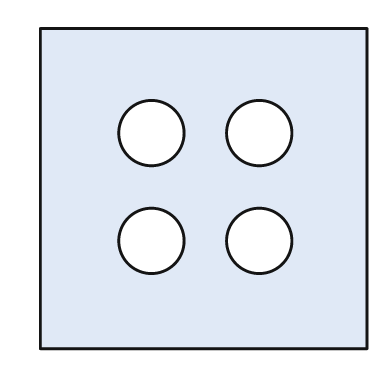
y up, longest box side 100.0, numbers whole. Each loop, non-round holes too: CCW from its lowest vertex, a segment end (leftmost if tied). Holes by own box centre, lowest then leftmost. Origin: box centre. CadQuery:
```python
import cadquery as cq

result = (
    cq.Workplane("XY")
    .moveTo(-50.0, -49.0)
    .lineTo(50.0, -49.0)
    .lineTo(50.0, 49.0)
    .lineTo(-50.0, 49.0)
    .close()
    .moveTo(-16.0, -16.0)
    .circle(10.0)
    .moveTo(17.0, -16.0)
    .circle(10.0)
    .moveTo(-16.0, 17.0)
    .circle(10.0)
    .moveTo(17.0, 17.0)
    .circle(10.0)
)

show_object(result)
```